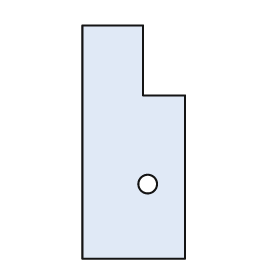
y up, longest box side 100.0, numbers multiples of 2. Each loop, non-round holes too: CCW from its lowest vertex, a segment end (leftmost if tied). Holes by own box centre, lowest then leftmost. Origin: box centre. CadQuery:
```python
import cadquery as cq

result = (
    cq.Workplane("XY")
    .moveTo(-22.0, -50.0)
    .lineTo(22.0, -50.0)
    .lineTo(22.0, 20.0)
    .lineTo(4.0, 20.0)
    .lineTo(4.0, 50.0)
    .lineTo(-22.0, 50.0)
    .close()
    .moveTo(6.0, -18.0)
    .circle(4.0)
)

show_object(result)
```